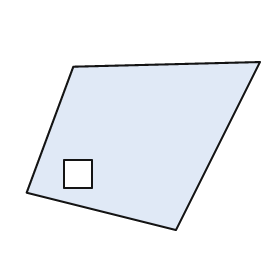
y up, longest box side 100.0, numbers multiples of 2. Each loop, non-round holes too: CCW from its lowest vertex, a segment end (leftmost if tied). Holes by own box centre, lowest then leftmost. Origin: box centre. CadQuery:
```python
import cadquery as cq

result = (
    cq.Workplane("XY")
    .moveTo(14.0, -36.0)
    .lineTo(50.0, 36.0)
    .lineTo(-30.0, 34.0)
    .lineTo(-50.0, -20.0)
    .close()
    .moveTo(-34.0, -18.0)
    .lineTo(-22.0, -18.0)
    .lineTo(-22.0, -6.0)
    .lineTo(-34.0, -6.0)
    .close()
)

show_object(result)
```